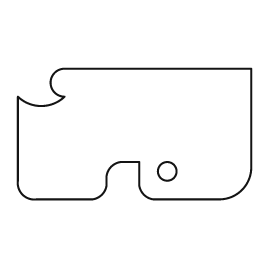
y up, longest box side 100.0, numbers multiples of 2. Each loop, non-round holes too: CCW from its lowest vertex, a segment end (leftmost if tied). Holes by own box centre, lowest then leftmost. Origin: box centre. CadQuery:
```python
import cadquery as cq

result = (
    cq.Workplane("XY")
    .moveTo(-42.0, -28.0)
    .lineTo(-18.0, -28.0)
    .threePointArc((-14.0, -26.0), (-12.0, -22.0))
    .lineTo(-12.0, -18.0)
    .threePointArc((-10.0, -14.0), (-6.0, -12.0))
    .lineTo(2.0, -12.0)
    .lineTo(2.0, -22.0)
    .threePointArc((4.0, -26.0), (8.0, -28.0))
    .lineTo(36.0, -28.0)
    .threePointArc((46.0, -24.0), (50.0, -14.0))
    .lineTo(50.0, 28.0)
    .lineTo(-30.0, 28.0)
    .threePointArc((-36.0, 22.0), (-30.0, 16.0))
    .threePointArc((-40.0, 12.0), (-50.0, 16.0))
    .lineTo(-50.0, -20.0)
    .threePointArc((-48.0, -26.0), (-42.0, -28.0))
    .close()
    .moveTo(14.0, -16.0)
    .circle(4.0)
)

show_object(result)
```